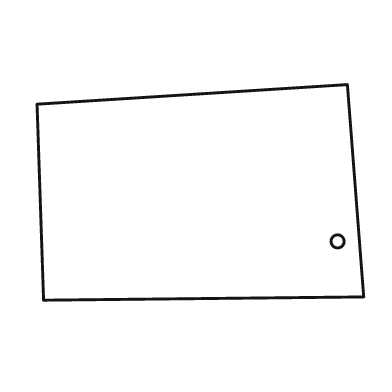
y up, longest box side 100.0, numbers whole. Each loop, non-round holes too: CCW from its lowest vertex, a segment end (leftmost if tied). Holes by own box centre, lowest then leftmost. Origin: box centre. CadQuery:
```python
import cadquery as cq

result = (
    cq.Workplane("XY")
    .moveTo(-48.0, -33.0)
    .lineTo(50.0, -32.0)
    .lineTo(45.0, 33.0)
    .lineTo(-50.0, 27.0)
    .close()
    .moveTo(42.0, -15.0)
    .circle(2.0)
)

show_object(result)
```